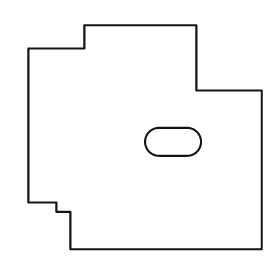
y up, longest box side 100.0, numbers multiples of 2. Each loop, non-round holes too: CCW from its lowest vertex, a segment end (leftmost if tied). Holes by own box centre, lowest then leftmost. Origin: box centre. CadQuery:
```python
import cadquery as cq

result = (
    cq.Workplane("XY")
    .moveTo(-32.0, -48.0)
    .lineTo(50.0, -48.0)
    .lineTo(50.0, 20.0)
    .lineTo(22.0, 20.0)
    .lineTo(22.0, 48.0)
    .lineTo(-26.0, 48.0)
    .lineTo(-26.0, 38.0)
    .lineTo(-50.0, 38.0)
    .lineTo(-50.0, -28.0)
    .lineTo(-38.0, -28.0)
    .lineTo(-38.0, -32.0)
    .lineTo(-32.0, -32.0)
    .close()
    .moveTo(6.0, -8.0)
    .lineTo(18.0, -8.0)
    .threePointArc((24.0, -2.0), (18.0, 4.0))
    .lineTo(6.0, 4.0)
    .threePointArc((0.0, -2.0), (6.0, -8.0))
    .close()
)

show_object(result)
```